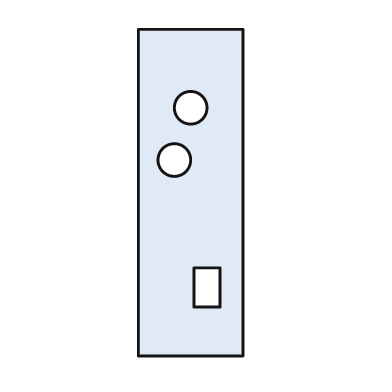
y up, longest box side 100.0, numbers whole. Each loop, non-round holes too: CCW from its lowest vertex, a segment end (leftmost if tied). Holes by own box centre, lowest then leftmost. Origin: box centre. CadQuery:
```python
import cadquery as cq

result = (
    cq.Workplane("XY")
    .moveTo(-16.0, -50.0)
    .lineTo(16.0, -50.0)
    .lineTo(16.0, 50.0)
    .lineTo(-16.0, 50.0)
    .close()
    .moveTo(1.0, -35.0)
    .lineTo(9.0, -35.0)
    .lineTo(9.0, -23.0)
    .lineTo(1.0, -23.0)
    .close()
    .moveTo(-5.0, 10.0)
    .circle(5.0)
    .moveTo(0.0, 26.0)
    .circle(5.0)
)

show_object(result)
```